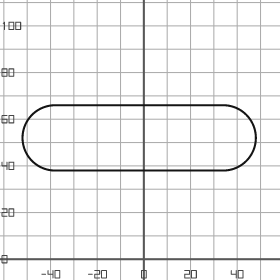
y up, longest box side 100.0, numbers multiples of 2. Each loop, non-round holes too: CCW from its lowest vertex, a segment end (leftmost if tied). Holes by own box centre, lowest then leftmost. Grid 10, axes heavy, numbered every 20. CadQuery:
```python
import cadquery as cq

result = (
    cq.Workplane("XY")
    .moveTo(-38.0, 38.0)
    .lineTo(34.0, 38.0)
    .threePointArc((48.0, 52.0), (34.0, 66.0))
    .lineTo(-38.0, 66.0)
    .threePointArc((-52.0, 52.0), (-38.0, 38.0))
    .close()
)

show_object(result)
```